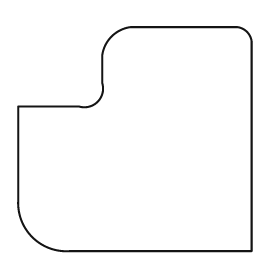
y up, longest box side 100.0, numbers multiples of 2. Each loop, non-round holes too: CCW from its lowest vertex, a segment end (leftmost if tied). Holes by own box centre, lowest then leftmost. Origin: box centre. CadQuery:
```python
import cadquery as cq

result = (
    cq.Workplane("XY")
    .moveTo(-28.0, -48.0)
    .lineTo(50.0, -48.0)
    .lineTo(50.0, 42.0)
    .threePointArc((48.0, 46.0), (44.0, 48.0))
    .lineTo(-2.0, 48.0)
    .threePointArc((-10.0, 44.0), (-14.0, 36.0))
    .lineTo(-14.0, 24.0)
    .threePointArc((-16.0, 16.0), (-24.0, 14.0))
    .lineTo(-50.0, 14.0)
    .lineTo(-50.0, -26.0)
    .threePointArc((-44.0, -42.0), (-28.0, -48.0))
    .close()
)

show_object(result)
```